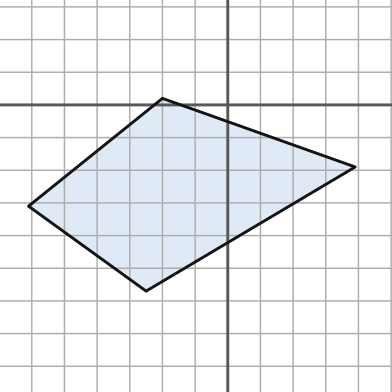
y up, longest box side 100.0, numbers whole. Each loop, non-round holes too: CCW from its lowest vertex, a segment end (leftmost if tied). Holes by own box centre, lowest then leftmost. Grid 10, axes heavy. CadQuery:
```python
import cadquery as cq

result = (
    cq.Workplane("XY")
    .moveTo(-25.0, -57.0)
    .lineTo(39.0, -19.0)
    .lineTo(-20.0, 2.0)
    .lineTo(-61.0, -31.0)
    .close()
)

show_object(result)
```